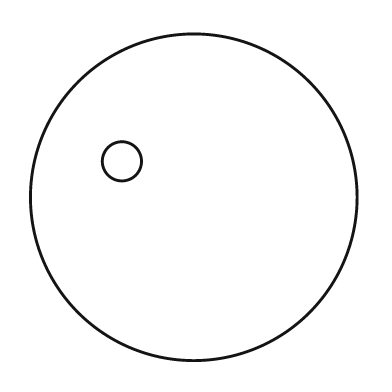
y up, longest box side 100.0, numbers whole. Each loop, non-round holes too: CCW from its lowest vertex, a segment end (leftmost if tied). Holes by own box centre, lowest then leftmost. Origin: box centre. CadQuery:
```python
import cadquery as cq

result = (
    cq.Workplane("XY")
    .moveTo(0.0, 0.0)
    .circle(50.0)
    .moveTo(-22.0, 11.0)
    .circle(6.0)
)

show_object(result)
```